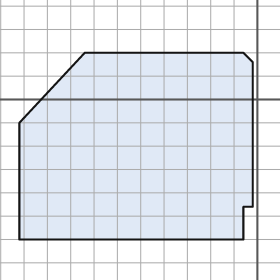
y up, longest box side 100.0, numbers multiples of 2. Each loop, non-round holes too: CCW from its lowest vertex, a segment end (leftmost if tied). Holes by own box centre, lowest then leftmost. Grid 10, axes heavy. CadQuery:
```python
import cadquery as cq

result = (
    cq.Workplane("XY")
    .moveTo(-102.0, -60.0)
    .lineTo(-6.0, -60.0)
    .lineTo(-6.0, -46.0)
    .lineTo(-2.0, -46.0)
    .lineTo(-2.0, 16.0)
    .lineTo(-6.0, 20.0)
    .lineTo(-74.0, 20.0)
    .lineTo(-102.0, -10.0)
    .close()
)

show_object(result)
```